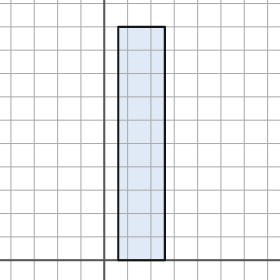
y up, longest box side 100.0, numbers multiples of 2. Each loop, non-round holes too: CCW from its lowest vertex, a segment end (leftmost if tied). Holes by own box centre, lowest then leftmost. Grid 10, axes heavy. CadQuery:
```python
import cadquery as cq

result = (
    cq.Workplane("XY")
    .moveTo(6.0, 0.0)
    .lineTo(26.0, 0.0)
    .lineTo(26.0, 100.0)
    .lineTo(6.0, 100.0)
    .close()
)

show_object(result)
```